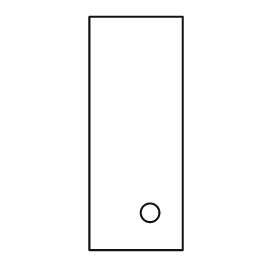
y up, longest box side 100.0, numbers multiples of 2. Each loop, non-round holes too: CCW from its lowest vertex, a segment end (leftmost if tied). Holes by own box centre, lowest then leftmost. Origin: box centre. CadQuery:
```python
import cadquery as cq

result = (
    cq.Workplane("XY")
    .moveTo(-20.0, -50.0)
    .lineTo(20.0, -50.0)
    .lineTo(20.0, 50.0)
    .lineTo(-20.0, 50.0)
    .close()
    .moveTo(6.0, -34.0)
    .circle(4.0)
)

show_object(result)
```